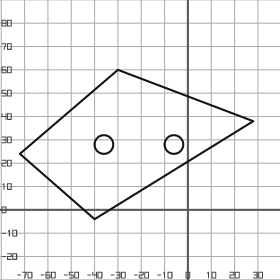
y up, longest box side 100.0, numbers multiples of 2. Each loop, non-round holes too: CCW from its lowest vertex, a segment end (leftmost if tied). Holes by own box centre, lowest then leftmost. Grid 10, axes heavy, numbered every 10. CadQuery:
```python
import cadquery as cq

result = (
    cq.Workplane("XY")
    .moveTo(-40.0, -4.0)
    .lineTo(28.0, 38.0)
    .lineTo(-30.0, 60.0)
    .lineTo(-72.0, 24.0)
    .close()
    .moveTo(-36.0, 28.0)
    .circle(4.0)
    .moveTo(-6.0, 28.0)
    .circle(4.0)
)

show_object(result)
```